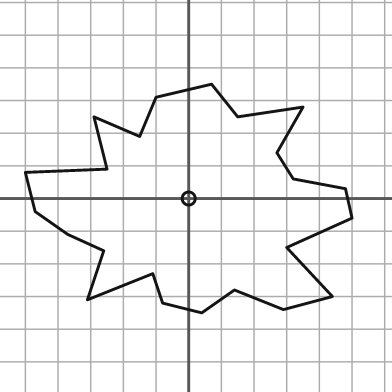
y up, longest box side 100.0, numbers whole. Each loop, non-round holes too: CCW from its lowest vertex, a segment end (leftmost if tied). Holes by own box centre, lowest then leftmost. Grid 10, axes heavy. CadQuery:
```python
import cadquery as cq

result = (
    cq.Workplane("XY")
    .moveTo(4.0, -35.0)
    .lineTo(14.0, -28.0)
    .lineTo(29.0, -34.0)
    .lineTo(44.0, -30.0)
    .lineTo(30.0, -15.0)
    .lineTo(50.0, -6.0)
    .lineTo(48.0, 3.0)
    .lineTo(32.0, 6.0)
    .lineTo(27.0, 14.0)
    .lineTo(35.0, 28.0)
    .lineTo(15.0, 25.0)
    .lineTo(7.0, 35.0)
    .lineTo(-10.0, 31.0)
    .lineTo(-15.0, 19.0)
    .lineTo(-29.0, 25.0)
    .lineTo(-25.0, 9.0)
    .lineTo(-50.0, 8.0)
    .lineTo(-47.0, -4.0)
    .lineTo(-37.0, -11.0)
    .lineTo(-26.0, -16.0)
    .lineTo(-31.0, -31.0)
    .lineTo(-11.0, -23.0)
    .lineTo(-8.0, -32.0)
    .close()
    .moveTo(0.0, 0.0)
    .circle(2.0)
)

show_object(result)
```